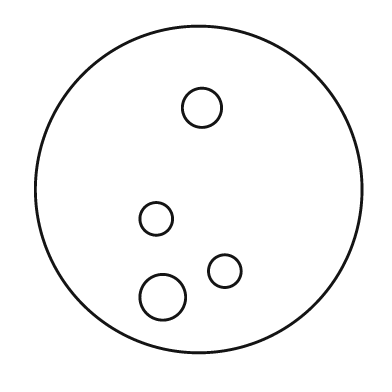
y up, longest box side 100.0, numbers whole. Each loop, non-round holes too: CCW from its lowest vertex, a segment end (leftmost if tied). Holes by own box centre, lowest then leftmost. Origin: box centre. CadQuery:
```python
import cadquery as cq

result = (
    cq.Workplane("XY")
    .moveTo(0.0, 0.0)
    .circle(50.0)
    .moveTo(-11.0, -33.0)
    .circle(7.0)
    .moveTo(8.0, -25.0)
    .circle(5.0)
    .moveTo(-13.0, -9.0)
    .circle(5.0)
    .moveTo(1.0, 25.0)
    .circle(6.0)
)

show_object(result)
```